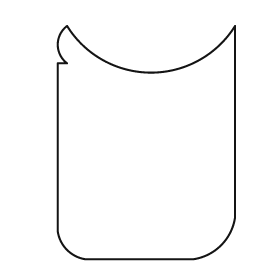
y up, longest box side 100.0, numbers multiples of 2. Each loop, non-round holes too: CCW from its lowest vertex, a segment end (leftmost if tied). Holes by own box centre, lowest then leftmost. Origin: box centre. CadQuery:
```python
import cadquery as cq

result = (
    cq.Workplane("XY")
    .moveTo(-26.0, -50.0)
    .lineTo(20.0, -50.0)
    .threePointArc((32.0, -44.0), (38.0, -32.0))
    .lineTo(38.0, 50.0)
    .threePointArc((2.0, 30.0), (-34.0, 50.0))
    .threePointArc((-38.0, 42.0), (-34.0, 34.0))
    .lineTo(-38.0, 34.0)
    .lineTo(-38.0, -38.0)
    .threePointArc((-34.0, -46.0), (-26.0, -50.0))
    .close()
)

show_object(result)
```